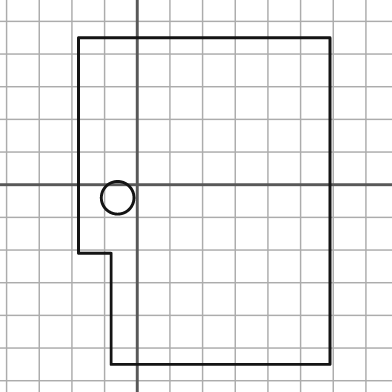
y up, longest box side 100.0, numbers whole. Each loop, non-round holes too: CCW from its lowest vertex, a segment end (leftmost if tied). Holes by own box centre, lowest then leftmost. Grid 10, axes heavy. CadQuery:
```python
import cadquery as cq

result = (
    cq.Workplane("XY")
    .moveTo(-8.0, -55.0)
    .lineTo(59.0, -55.0)
    .lineTo(59.0, 45.0)
    .lineTo(-18.0, 45.0)
    .lineTo(-18.0, -21.0)
    .lineTo(-8.0, -21.0)
    .close()
    .moveTo(-6.0, -4.0)
    .circle(5.0)
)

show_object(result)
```